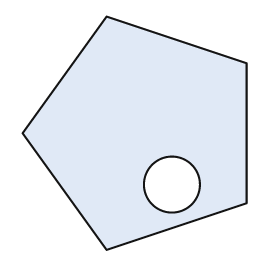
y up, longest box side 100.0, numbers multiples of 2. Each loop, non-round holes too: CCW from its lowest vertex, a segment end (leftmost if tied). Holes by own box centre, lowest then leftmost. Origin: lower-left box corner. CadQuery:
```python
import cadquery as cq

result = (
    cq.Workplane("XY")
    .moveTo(36.0, 0.0)
    .lineTo(96.0, 20.0)
    .lineTo(96.0, 80.0)
    .lineTo(36.0, 100.0)
    .lineTo(0.0, 50.0)
    .close()
    .moveTo(64.0, 28.0)
    .circle(12.0)
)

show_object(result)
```